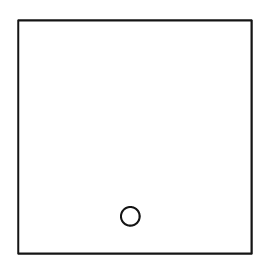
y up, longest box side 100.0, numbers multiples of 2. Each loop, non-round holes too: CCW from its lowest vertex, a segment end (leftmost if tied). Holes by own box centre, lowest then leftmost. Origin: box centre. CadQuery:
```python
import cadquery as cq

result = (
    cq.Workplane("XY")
    .moveTo(-50.0, -50.0)
    .lineTo(50.0, -50.0)
    .lineTo(50.0, 50.0)
    .lineTo(-50.0, 50.0)
    .close()
    .moveTo(-2.0, -34.0)
    .circle(4.0)
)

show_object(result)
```